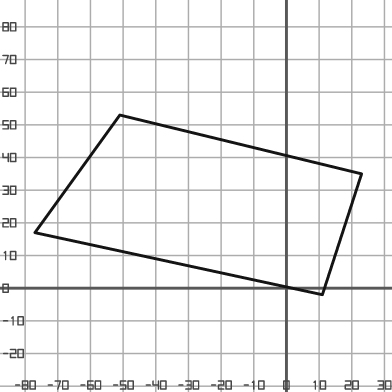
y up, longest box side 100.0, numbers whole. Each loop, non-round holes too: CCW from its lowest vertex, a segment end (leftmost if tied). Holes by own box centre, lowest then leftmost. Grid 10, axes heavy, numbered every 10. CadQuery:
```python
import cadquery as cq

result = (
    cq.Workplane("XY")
    .moveTo(11.0, -2.0)
    .lineTo(23.0, 35.0)
    .lineTo(-51.0, 53.0)
    .lineTo(-77.0, 17.0)
    .close()
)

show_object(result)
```